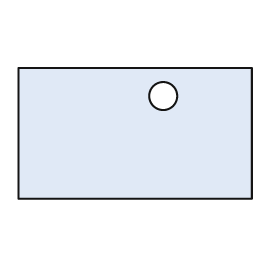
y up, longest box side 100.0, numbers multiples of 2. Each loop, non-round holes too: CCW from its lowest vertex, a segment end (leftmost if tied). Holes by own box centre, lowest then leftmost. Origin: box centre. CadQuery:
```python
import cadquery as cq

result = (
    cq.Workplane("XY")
    .moveTo(-50.0, -28.0)
    .lineTo(50.0, -28.0)
    .lineTo(50.0, 28.0)
    .lineTo(-50.0, 28.0)
    .close()
    .moveTo(12.0, 16.0)
    .circle(6.0)
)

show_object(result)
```